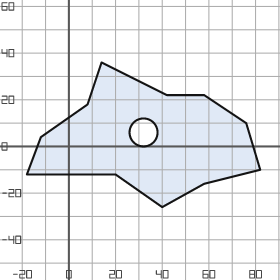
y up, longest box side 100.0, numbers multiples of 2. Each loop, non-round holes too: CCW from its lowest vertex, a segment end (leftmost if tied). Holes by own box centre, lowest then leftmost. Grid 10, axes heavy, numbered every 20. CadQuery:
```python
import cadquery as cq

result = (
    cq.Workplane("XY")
    .moveTo(40.0, -26.0)
    .lineTo(58.0, -16.0)
    .lineTo(82.0, -10.0)
    .lineTo(76.0, 10.0)
    .lineTo(58.0, 22.0)
    .lineTo(42.0, 22.0)
    .lineTo(14.0, 36.0)
    .lineTo(8.0, 18.0)
    .lineTo(-12.0, 4.0)
    .lineTo(-18.0, -12.0)
    .lineTo(20.0, -12.0)
    .close()
    .moveTo(32.0, 6.0)
    .circle(6.0)
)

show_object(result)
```